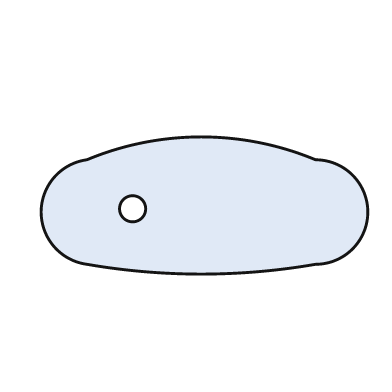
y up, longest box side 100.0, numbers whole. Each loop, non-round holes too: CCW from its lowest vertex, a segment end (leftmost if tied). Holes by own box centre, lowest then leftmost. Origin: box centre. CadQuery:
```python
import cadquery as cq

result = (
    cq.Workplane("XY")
    .moveTo(-36.0, -18.0)
    .threePointArc((-1.0, -21.0), (34.0, -18.0))
    .threePointArc((50.0, -2.0), (34.0, 14.0))
    .threePointArc((-1.0, 21.0), (-36.0, 14.0))
    .threePointArc((-50.0, -2.0), (-36.0, -18.0))
    .close()
    .moveTo(-22.0, -1.0)
    .circle(4.0)
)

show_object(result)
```